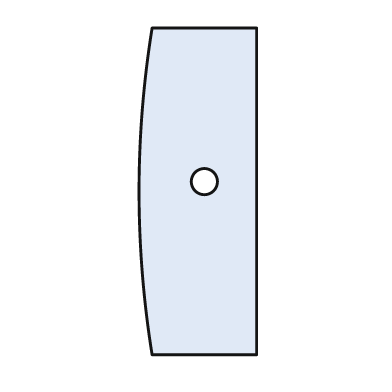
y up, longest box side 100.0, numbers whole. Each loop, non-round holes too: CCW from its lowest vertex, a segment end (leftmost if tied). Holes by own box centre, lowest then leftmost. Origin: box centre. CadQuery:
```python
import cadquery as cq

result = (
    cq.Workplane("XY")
    .moveTo(-14.0, -50.0)
    .lineTo(18.0, -50.0)
    .lineTo(18.0, 50.0)
    .lineTo(-14.0, 50.0)
    .threePointArc((-18.0, 0.0), (-14.0, -50.0))
    .close()
    .moveTo(2.0, 3.0)
    .circle(4.0)
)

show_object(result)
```